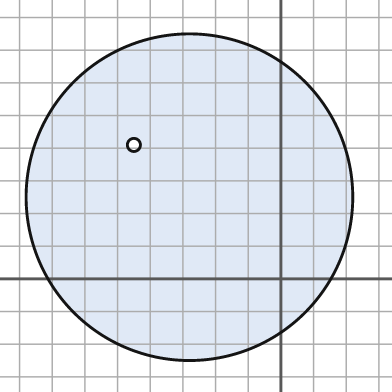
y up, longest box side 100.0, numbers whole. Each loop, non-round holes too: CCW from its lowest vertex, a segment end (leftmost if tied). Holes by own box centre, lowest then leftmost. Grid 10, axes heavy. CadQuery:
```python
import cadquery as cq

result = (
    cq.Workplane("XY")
    .moveTo(-28.0, 25.0)
    .circle(50.0)
    .moveTo(-45.0, 41.0)
    .circle(2.0)
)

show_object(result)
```